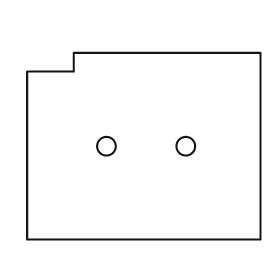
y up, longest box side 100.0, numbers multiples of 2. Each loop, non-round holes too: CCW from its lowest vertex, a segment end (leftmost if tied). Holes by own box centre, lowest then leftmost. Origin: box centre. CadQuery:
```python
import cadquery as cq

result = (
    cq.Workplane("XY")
    .moveTo(-50.0, -40.0)
    .lineTo(50.0, -40.0)
    .lineTo(50.0, 40.0)
    .lineTo(-30.0, 40.0)
    .lineTo(-30.0, 32.0)
    .lineTo(-50.0, 32.0)
    .close()
    .moveTo(-16.0, 0.0)
    .circle(4.0)
    .moveTo(18.0, 0.0)
    .circle(4.0)
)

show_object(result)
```